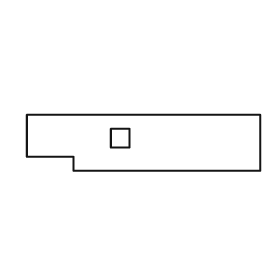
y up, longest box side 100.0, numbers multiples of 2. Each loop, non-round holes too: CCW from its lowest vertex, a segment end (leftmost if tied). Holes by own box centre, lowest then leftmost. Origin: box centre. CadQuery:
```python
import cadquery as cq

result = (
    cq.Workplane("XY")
    .moveTo(-30.0, -12.0)
    .lineTo(50.0, -12.0)
    .lineTo(50.0, 12.0)
    .lineTo(-50.0, 12.0)
    .lineTo(-50.0, -6.0)
    .lineTo(-30.0, -6.0)
    .close()
    .moveTo(-14.0, -2.0)
    .lineTo(-6.0, -2.0)
    .lineTo(-6.0, 6.0)
    .lineTo(-14.0, 6.0)
    .close()
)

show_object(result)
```